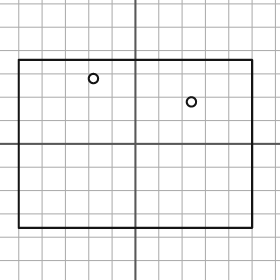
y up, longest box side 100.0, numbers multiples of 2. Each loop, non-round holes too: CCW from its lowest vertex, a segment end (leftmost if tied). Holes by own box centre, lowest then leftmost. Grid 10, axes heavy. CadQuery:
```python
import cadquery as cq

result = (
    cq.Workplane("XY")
    .moveTo(-50.0, -36.0)
    .lineTo(50.0, -36.0)
    .lineTo(50.0, 36.0)
    .lineTo(-50.0, 36.0)
    .close()
    .moveTo(24.0, 18.0)
    .circle(2.0)
    .moveTo(-18.0, 28.0)
    .circle(2.0)
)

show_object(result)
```